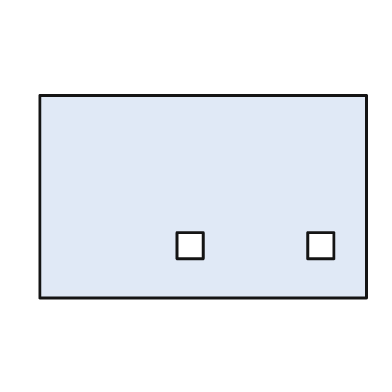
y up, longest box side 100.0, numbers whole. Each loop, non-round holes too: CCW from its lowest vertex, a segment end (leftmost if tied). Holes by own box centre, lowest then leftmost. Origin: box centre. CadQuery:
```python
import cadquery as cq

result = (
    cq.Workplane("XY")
    .moveTo(-50.0, -31.0)
    .lineTo(50.0, -31.0)
    .lineTo(50.0, 31.0)
    .lineTo(-50.0, 31.0)
    .close()
    .moveTo(-8.0, -19.0)
    .lineTo(0.0, -19.0)
    .lineTo(0.0, -11.0)
    .lineTo(-8.0, -11.0)
    .close()
    .moveTo(32.0, -19.0)
    .lineTo(40.0, -19.0)
    .lineTo(40.0, -11.0)
    .lineTo(32.0, -11.0)
    .close()
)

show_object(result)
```